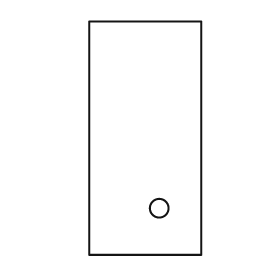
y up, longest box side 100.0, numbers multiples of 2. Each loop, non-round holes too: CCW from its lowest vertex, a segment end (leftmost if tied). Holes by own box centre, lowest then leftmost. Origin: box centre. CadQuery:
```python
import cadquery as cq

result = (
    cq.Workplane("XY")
    .moveTo(-24.0, -50.0)
    .lineTo(24.0, -50.0)
    .lineTo(24.0, 50.0)
    .lineTo(-24.0, 50.0)
    .close()
    .moveTo(6.0, -30.0)
    .circle(4.0)
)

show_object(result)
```